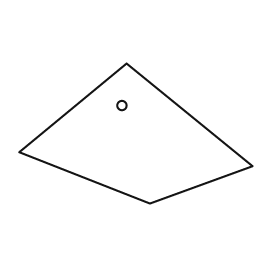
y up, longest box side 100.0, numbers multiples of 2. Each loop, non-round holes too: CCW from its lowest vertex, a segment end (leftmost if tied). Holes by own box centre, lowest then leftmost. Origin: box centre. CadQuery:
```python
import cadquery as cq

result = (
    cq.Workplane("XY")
    .moveTo(6.0, -30.0)
    .lineTo(50.0, -14.0)
    .lineTo(-4.0, 30.0)
    .lineTo(-50.0, -8.0)
    .close()
    .moveTo(-6.0, 12.0)
    .circle(2.0)
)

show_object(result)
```